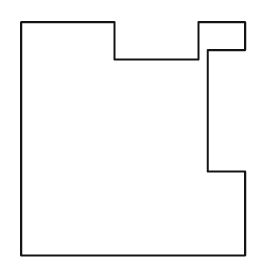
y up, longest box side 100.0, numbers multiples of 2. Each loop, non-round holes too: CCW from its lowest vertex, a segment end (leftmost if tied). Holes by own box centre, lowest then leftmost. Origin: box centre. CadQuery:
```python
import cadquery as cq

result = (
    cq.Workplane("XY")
    .moveTo(-48.0, -50.0)
    .lineTo(48.0, -50.0)
    .lineTo(48.0, -14.0)
    .lineTo(32.0, -14.0)
    .lineTo(32.0, 38.0)
    .lineTo(48.0, 38.0)
    .lineTo(48.0, 50.0)
    .lineTo(28.0, 50.0)
    .lineTo(28.0, 34.0)
    .lineTo(-8.0, 34.0)
    .lineTo(-8.0, 50.0)
    .lineTo(-48.0, 50.0)
    .close()
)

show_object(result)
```